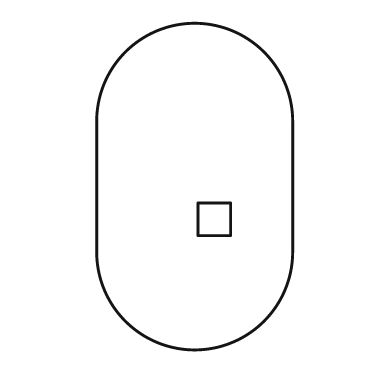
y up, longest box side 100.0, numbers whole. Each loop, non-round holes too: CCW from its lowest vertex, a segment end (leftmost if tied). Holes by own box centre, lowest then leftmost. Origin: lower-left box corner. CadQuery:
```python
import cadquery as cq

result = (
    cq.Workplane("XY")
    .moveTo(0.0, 30.0)
    .threePointArc((30.0, 0.0), (60.0, 30.0))
    .lineTo(60.0, 70.0)
    .threePointArc((30.0, 100.0), (0.0, 70.0))
    .close()
    .moveTo(31.0, 35.0)
    .lineTo(41.0, 35.0)
    .lineTo(41.0, 45.0)
    .lineTo(31.0, 45.0)
    .close()
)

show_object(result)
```